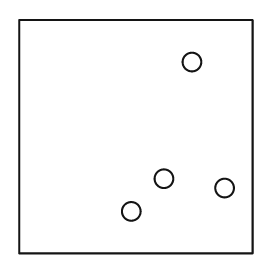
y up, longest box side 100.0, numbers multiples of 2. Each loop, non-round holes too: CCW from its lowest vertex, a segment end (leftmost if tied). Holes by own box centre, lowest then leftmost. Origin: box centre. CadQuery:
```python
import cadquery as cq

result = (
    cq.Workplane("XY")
    .moveTo(-50.0, -50.0)
    .lineTo(50.0, -50.0)
    .lineTo(50.0, 50.0)
    .lineTo(-50.0, 50.0)
    .close()
    .moveTo(-2.0, -32.0)
    .circle(4.0)
    .moveTo(38.0, -22.0)
    .circle(4.0)
    .moveTo(12.0, -18.0)
    .circle(4.0)
    .moveTo(24.0, 32.0)
    .circle(4.0)
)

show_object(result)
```